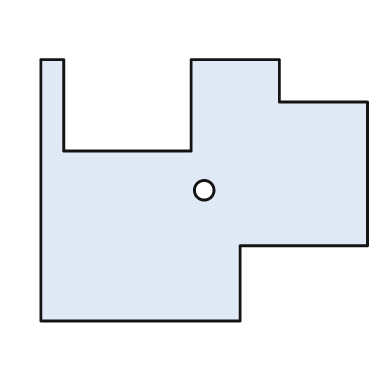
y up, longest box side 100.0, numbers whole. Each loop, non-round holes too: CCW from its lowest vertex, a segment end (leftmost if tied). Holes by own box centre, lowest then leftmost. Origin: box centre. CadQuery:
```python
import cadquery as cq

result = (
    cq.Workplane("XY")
    .moveTo(-50.0, -40.0)
    .lineTo(11.0, -40.0)
    .lineTo(11.0, -17.0)
    .lineTo(50.0, -17.0)
    .lineTo(50.0, 27.0)
    .lineTo(23.0, 27.0)
    .lineTo(23.0, 40.0)
    .lineTo(-4.0, 40.0)
    .lineTo(-4.0, 12.0)
    .lineTo(-43.0, 12.0)
    .lineTo(-43.0, 40.0)
    .lineTo(-50.0, 40.0)
    .close()
    .moveTo(0.0, 0.0)
    .circle(3.0)
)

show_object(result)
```